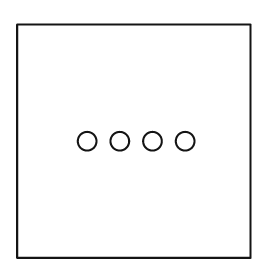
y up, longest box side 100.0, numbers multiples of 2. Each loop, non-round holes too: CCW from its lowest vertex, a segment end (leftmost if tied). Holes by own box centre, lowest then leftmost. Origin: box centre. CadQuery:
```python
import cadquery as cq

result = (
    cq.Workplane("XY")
    .moveTo(-50.0, -50.0)
    .lineTo(50.0, -50.0)
    .lineTo(50.0, 50.0)
    .lineTo(-50.0, 50.0)
    .close()
    .moveTo(-20.0, 0.0)
    .circle(4.0)
    .moveTo(-6.0, 0.0)
    .circle(4.0)
    .moveTo(8.0, 0.0)
    .circle(4.0)
    .moveTo(22.0, 0.0)
    .circle(4.0)
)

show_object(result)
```